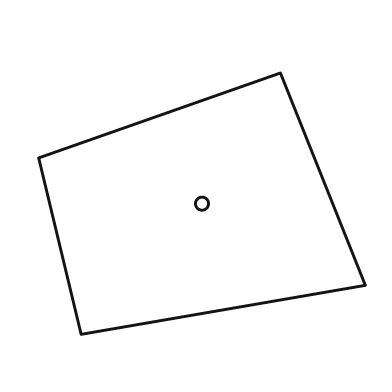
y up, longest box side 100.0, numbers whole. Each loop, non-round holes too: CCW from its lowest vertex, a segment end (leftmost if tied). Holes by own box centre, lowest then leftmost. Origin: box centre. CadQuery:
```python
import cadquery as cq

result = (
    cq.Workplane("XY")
    .moveTo(-37.0, -40.0)
    .lineTo(50.0, -25.0)
    .lineTo(24.0, 40.0)
    .lineTo(-50.0, 14.0)
    .close()
    .moveTo(0.0, 0.0)
    .circle(2.0)
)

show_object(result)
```